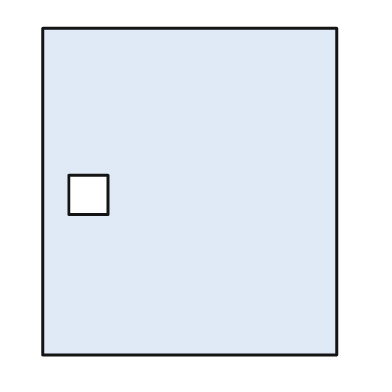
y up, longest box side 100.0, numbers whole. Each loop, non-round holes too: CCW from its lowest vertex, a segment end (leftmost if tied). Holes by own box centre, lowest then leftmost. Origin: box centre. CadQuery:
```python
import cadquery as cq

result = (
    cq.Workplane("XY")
    .moveTo(-45.0, -50.0)
    .lineTo(45.0, -50.0)
    .lineTo(45.0, 50.0)
    .lineTo(-45.0, 50.0)
    .close()
    .moveTo(-37.0, -7.0)
    .lineTo(-25.0, -7.0)
    .lineTo(-25.0, 5.0)
    .lineTo(-37.0, 5.0)
    .close()
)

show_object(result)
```